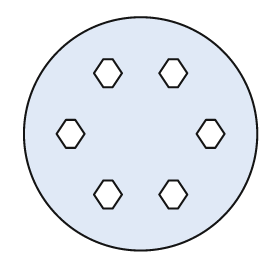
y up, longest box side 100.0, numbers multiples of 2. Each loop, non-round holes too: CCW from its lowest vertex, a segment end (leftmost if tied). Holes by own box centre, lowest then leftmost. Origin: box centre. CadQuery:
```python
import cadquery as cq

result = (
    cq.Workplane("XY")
    .moveTo(0.0, 0.0)
    .circle(50.0)
    .moveTo(-16.0, -32.0)
    .lineTo(-12.0, -32.0)
    .lineTo(-8.0, -26.0)
    .lineTo(-12.0, -20.0)
    .lineTo(-16.0, -20.0)
    .lineTo(-20.0, -26.0)
    .close()
    .moveTo(12.0, -32.0)
    .lineTo(16.0, -32.0)
    .lineTo(20.0, -26.0)
    .lineTo(16.0, -20.0)
    .lineTo(12.0, -20.0)
    .lineTo(8.0, -26.0)
    .close()
    .moveTo(-32.0, -6.0)
    .lineTo(-28.0, -6.0)
    .lineTo(-24.0, 0.0)
    .lineTo(-28.0, 6.0)
    .lineTo(-32.0, 6.0)
    .lineTo(-36.0, 0.0)
    .close()
    .moveTo(28.0, -6.0)
    .lineTo(32.0, -6.0)
    .lineTo(36.0, 0.0)
    .lineTo(32.0, 6.0)
    .lineTo(28.0, 6.0)
    .lineTo(24.0, 0.0)
    .close()
    .moveTo(-16.0, 20.0)
    .lineTo(-12.0, 20.0)
    .lineTo(-8.0, 26.0)
    .lineTo(-12.0, 32.0)
    .lineTo(-16.0, 32.0)
    .lineTo(-20.0, 26.0)
    .close()
    .moveTo(12.0, 20.0)
    .lineTo(16.0, 20.0)
    .lineTo(20.0, 26.0)
    .lineTo(16.0, 32.0)
    .lineTo(12.0, 32.0)
    .lineTo(8.0, 26.0)
    .close()
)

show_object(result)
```